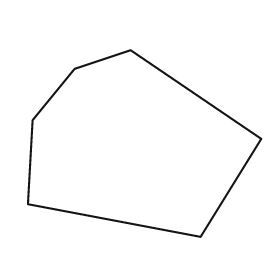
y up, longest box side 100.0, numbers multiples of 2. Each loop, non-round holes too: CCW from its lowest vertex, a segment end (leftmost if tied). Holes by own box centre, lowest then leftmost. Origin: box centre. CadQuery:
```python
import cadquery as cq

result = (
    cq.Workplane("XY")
    .moveTo(24.0, -40.0)
    .lineTo(50.0, 2.0)
    .lineTo(-6.0, 40.0)
    .lineTo(-30.0, 32.0)
    .lineTo(-48.0, 10.0)
    .lineTo(-50.0, -26.0)
    .close()
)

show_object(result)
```